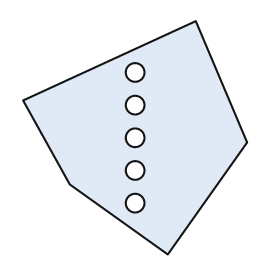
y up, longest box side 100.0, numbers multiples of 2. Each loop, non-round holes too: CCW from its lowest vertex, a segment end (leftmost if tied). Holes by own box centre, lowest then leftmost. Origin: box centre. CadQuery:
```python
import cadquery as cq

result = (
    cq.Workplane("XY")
    .moveTo(14.0, -50.0)
    .lineTo(48.0, -2.0)
    .lineTo(26.0, 50.0)
    .lineTo(-48.0, 16.0)
    .lineTo(-28.0, -20.0)
    .close()
    .moveTo(0.0, -28.0)
    .circle(4.0)
    .moveTo(0.0, -14.0)
    .circle(4.0)
    .moveTo(0.0, 0.0)
    .circle(4.0)
    .moveTo(0.0, 14.0)
    .circle(4.0)
    .moveTo(0.0, 28.0)
    .circle(4.0)
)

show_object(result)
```